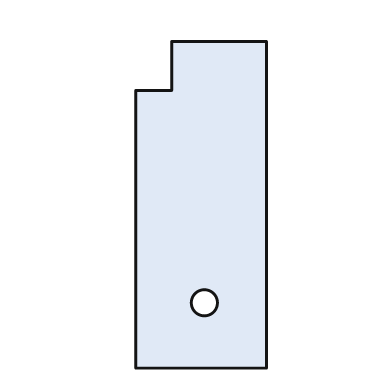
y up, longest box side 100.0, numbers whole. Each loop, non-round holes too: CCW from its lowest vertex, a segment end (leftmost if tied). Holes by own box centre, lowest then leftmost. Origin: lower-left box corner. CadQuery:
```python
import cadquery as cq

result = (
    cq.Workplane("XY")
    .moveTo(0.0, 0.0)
    .lineTo(40.0, 0.0)
    .lineTo(40.0, 100.0)
    .lineTo(11.0, 100.0)
    .lineTo(11.0, 85.0)
    .lineTo(0.0, 85.0)
    .close()
    .moveTo(21.0, 20.0)
    .circle(4.0)
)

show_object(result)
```